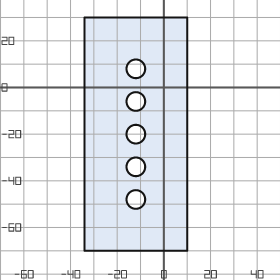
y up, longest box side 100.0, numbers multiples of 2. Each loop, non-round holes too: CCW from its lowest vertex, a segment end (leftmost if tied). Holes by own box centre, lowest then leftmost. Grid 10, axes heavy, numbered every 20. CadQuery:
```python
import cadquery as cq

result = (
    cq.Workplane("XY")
    .moveTo(-34.0, -70.0)
    .lineTo(10.0, -70.0)
    .lineTo(10.0, 30.0)
    .lineTo(-34.0, 30.0)
    .close()
    .moveTo(-12.0, -48.0)
    .circle(4.0)
    .moveTo(-12.0, -34.0)
    .circle(4.0)
    .moveTo(-12.0, -20.0)
    .circle(4.0)
    .moveTo(-12.0, -6.0)
    .circle(4.0)
    .moveTo(-12.0, 8.0)
    .circle(4.0)
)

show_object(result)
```